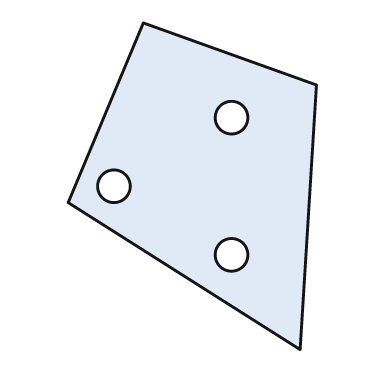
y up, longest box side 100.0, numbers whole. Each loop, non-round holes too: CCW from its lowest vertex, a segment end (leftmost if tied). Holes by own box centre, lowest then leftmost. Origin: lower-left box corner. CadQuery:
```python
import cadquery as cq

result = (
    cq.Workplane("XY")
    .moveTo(71.0, 0.0)
    .lineTo(76.0, 81.0)
    .lineTo(23.0, 100.0)
    .lineTo(0.0, 45.0)
    .close()
    .moveTo(50.0, 29.0)
    .circle(5.0)
    .moveTo(14.0, 50.0)
    .circle(5.0)
    .moveTo(50.0, 71.0)
    .circle(5.0)
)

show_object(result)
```